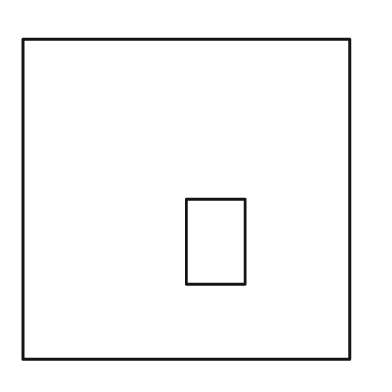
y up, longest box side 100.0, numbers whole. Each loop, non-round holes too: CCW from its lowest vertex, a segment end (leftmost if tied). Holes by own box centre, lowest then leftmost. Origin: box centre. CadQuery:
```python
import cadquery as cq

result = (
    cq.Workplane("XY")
    .moveTo(-50.0, -49.0)
    .lineTo(50.0, -49.0)
    .lineTo(50.0, 49.0)
    .lineTo(-50.0, 49.0)
    .close()
    .moveTo(0.0, -26.0)
    .lineTo(18.0, -26.0)
    .lineTo(18.0, 0.0)
    .lineTo(0.0, 0.0)
    .close()
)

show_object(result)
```